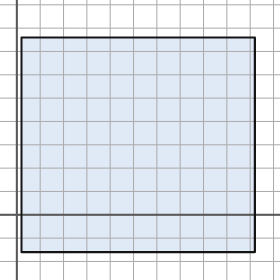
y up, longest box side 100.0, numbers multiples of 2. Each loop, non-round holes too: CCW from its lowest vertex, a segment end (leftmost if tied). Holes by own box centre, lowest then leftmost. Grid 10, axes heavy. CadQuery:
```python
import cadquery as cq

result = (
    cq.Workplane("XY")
    .moveTo(2.0, -16.0)
    .lineTo(102.0, -16.0)
    .lineTo(102.0, 76.0)
    .lineTo(2.0, 76.0)
    .close()
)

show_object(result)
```